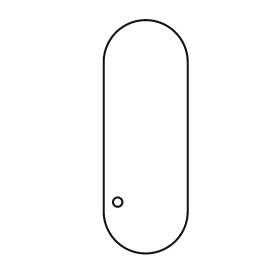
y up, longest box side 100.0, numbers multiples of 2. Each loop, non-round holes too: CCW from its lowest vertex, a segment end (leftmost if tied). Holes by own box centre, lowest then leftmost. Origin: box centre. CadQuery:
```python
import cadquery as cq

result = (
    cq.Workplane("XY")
    .moveTo(-18.0, -32.0)
    .threePointArc((0.0, -50.0), (18.0, -32.0))
    .lineTo(18.0, 32.0)
    .threePointArc((0.0, 50.0), (-18.0, 32.0))
    .close()
    .moveTo(-12.0, -28.0)
    .circle(2.0)
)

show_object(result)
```